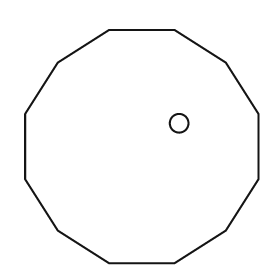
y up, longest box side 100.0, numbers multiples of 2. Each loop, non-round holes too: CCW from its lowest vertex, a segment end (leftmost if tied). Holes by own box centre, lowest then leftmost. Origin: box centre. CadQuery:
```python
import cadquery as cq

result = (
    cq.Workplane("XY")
    .moveTo(-14.0, -50.0)
    .lineTo(14.0, -50.0)
    .lineTo(36.0, -36.0)
    .lineTo(50.0, -14.0)
    .lineTo(50.0, 14.0)
    .lineTo(36.0, 36.0)
    .lineTo(14.0, 50.0)
    .lineTo(-14.0, 50.0)
    .lineTo(-36.0, 36.0)
    .lineTo(-50.0, 14.0)
    .lineTo(-50.0, -14.0)
    .lineTo(-36.0, -36.0)
    .close()
    .moveTo(16.0, 10.0)
    .circle(4.0)
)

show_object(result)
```